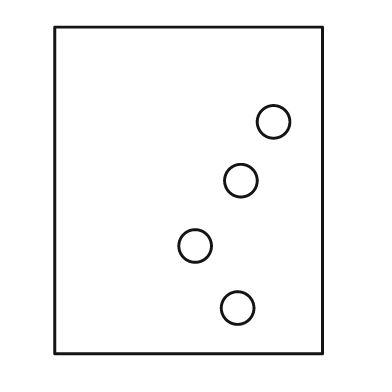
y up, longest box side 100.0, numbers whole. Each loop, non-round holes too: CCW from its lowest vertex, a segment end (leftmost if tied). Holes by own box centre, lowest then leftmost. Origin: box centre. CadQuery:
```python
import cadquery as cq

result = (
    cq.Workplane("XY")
    .moveTo(-41.0, -50.0)
    .lineTo(41.0, -50.0)
    .lineTo(41.0, 50.0)
    .lineTo(-41.0, 50.0)
    .close()
    .moveTo(15.0, -36.0)
    .circle(5.0)
    .moveTo(2.0, -17.0)
    .circle(5.0)
    .moveTo(16.0, 3.0)
    .circle(5.0)
    .moveTo(26.0, 21.0)
    .circle(5.0)
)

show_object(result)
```